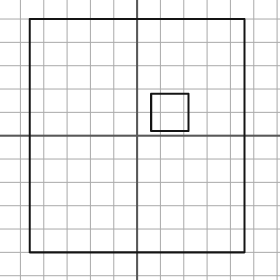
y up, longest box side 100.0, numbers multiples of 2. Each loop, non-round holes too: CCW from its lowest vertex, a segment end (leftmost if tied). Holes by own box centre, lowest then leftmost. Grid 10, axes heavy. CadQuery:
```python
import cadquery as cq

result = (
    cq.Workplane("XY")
    .moveTo(-46.0, -50.0)
    .lineTo(46.0, -50.0)
    .lineTo(46.0, 50.0)
    .lineTo(-46.0, 50.0)
    .close()
    .moveTo(6.0, 2.0)
    .lineTo(22.0, 2.0)
    .lineTo(22.0, 18.0)
    .lineTo(6.0, 18.0)
    .close()
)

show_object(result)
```